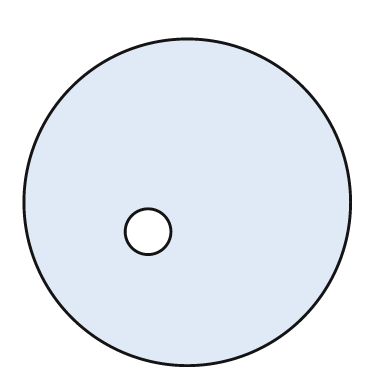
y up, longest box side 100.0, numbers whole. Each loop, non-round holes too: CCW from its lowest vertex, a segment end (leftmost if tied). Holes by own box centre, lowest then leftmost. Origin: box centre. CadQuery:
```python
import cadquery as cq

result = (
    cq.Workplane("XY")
    .moveTo(0.0, 0.0)
    .circle(50.0)
    .moveTo(-12.0, -9.0)
    .circle(7.0)
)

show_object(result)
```